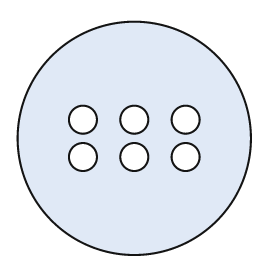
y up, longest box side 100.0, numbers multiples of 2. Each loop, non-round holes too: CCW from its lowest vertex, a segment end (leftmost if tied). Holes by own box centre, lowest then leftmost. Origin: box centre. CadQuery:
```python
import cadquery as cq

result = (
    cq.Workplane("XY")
    .moveTo(0.0, 0.0)
    .circle(50.0)
    .moveTo(-22.0, -8.0)
    .circle(6.0)
    .moveTo(0.0, -8.0)
    .circle(6.0)
    .moveTo(22.0, -8.0)
    .circle(6.0)
    .moveTo(-22.0, 8.0)
    .circle(6.0)
    .moveTo(0.0, 8.0)
    .circle(6.0)
    .moveTo(22.0, 8.0)
    .circle(6.0)
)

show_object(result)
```